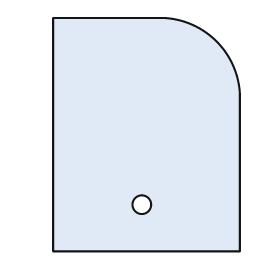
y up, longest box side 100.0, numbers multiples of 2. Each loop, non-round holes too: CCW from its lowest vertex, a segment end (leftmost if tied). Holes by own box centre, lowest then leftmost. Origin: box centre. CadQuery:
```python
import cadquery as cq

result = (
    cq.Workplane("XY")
    .moveTo(-40.0, -50.0)
    .lineTo(40.0, -50.0)
    .lineTo(40.0, 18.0)
    .threePointArc((30.0, 40.0), (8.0, 50.0))
    .lineTo(-40.0, 50.0)
    .close()
    .moveTo(-2.0, -30.0)
    .circle(4.0)
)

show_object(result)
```